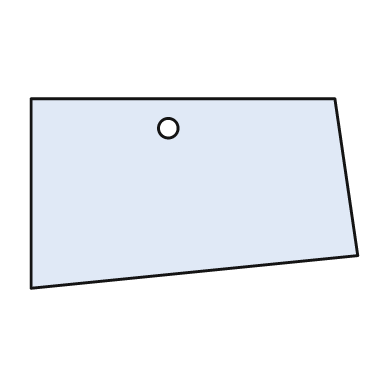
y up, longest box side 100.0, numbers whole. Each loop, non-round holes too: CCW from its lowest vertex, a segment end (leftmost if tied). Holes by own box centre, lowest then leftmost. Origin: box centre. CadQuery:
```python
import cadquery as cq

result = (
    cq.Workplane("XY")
    .moveTo(-50.0, -29.0)
    .lineTo(50.0, -19.0)
    .lineTo(43.0, 29.0)
    .lineTo(-50.0, 29.0)
    .close()
    .moveTo(-8.0, 20.0)
    .circle(3.0)
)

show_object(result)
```